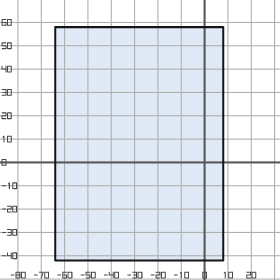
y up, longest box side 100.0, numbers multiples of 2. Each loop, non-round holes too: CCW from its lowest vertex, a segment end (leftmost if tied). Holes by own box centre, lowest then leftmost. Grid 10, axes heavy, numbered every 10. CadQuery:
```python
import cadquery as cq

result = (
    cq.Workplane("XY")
    .moveTo(-64.0, -42.0)
    .lineTo(8.0, -42.0)
    .lineTo(8.0, 58.0)
    .lineTo(-64.0, 58.0)
    .close()
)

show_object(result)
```